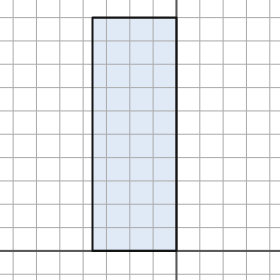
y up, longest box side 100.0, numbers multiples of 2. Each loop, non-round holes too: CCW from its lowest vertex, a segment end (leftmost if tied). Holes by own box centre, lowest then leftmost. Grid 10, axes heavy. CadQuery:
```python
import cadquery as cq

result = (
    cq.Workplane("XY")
    .moveTo(-36.0, 0.0)
    .lineTo(0.0, 0.0)
    .lineTo(0.0, 100.0)
    .lineTo(-36.0, 100.0)
    .close()
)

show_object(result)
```